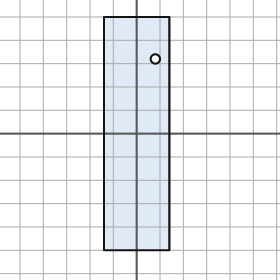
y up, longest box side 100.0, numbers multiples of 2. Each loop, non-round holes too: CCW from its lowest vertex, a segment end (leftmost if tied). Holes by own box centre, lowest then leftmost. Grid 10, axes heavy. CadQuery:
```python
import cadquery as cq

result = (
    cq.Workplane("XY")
    .moveTo(-14.0, -50.0)
    .lineTo(14.0, -50.0)
    .lineTo(14.0, 50.0)
    .lineTo(-14.0, 50.0)
    .close()
    .moveTo(8.0, 32.0)
    .circle(2.0)
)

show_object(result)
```